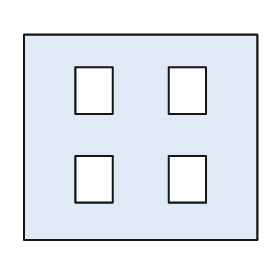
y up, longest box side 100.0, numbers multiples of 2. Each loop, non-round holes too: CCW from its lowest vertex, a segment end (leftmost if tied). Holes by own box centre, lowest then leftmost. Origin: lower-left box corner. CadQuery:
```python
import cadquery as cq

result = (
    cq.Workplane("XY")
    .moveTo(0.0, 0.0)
    .lineTo(100.0, 0.0)
    .lineTo(100.0, 88.0)
    .lineTo(0.0, 88.0)
    .close()
    .moveTo(22.0, 16.0)
    .lineTo(38.0, 16.0)
    .lineTo(38.0, 36.0)
    .lineTo(22.0, 36.0)
    .close()
    .moveTo(62.0, 16.0)
    .lineTo(78.0, 16.0)
    .lineTo(78.0, 36.0)
    .lineTo(62.0, 36.0)
    .close()
    .moveTo(22.0, 54.0)
    .lineTo(38.0, 54.0)
    .lineTo(38.0, 74.0)
    .lineTo(22.0, 74.0)
    .close()
    .moveTo(62.0, 54.0)
    .lineTo(78.0, 54.0)
    .lineTo(78.0, 74.0)
    .lineTo(62.0, 74.0)
    .close()
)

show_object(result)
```